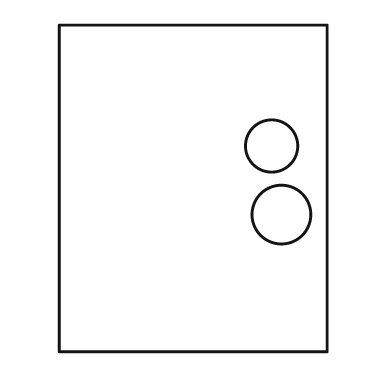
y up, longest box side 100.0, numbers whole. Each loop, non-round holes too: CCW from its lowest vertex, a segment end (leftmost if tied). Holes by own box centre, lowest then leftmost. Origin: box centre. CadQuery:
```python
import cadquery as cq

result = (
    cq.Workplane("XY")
    .moveTo(-41.0, -50.0)
    .lineTo(41.0, -50.0)
    .lineTo(41.0, 50.0)
    .lineTo(-41.0, 50.0)
    .close()
    .moveTo(27.0, -8.0)
    .circle(9.0)
    .moveTo(24.0, 13.0)
    .circle(8.0)
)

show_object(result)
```